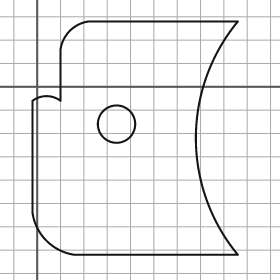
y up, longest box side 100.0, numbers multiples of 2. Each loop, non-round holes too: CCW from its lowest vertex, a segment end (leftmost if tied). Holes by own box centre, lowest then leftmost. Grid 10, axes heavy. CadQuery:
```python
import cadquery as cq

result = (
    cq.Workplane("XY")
    .moveTo(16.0, -72.0)
    .lineTo(86.0, -72.0)
    .threePointArc((68.0, -22.0), (86.0, 28.0))
    .lineTo(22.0, 28.0)
    .threePointArc((14.0, 24.0), (10.0, 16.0))
    .lineTo(10.0, -6.0)
    .threePointArc((4.0, -4.0), (-2.0, -6.0))
    .lineTo(-2.0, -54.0)
    .threePointArc((4.0, -66.0), (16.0, -72.0))
    .close()
    .moveTo(34.0, -16.0)
    .circle(8.0)
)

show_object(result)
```